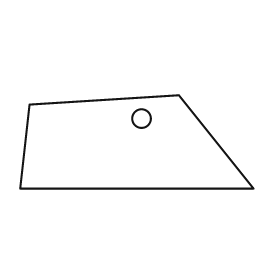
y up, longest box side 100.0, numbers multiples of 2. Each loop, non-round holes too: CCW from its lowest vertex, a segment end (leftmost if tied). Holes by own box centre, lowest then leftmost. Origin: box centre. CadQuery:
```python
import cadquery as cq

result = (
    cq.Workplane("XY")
    .moveTo(-50.0, -20.0)
    .lineTo(50.0, -20.0)
    .lineTo(18.0, 20.0)
    .lineTo(-46.0, 16.0)
    .close()
    .moveTo(2.0, 10.0)
    .circle(4.0)
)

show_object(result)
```